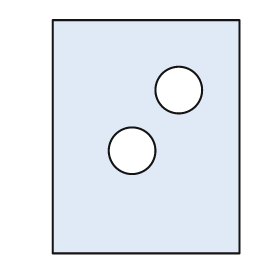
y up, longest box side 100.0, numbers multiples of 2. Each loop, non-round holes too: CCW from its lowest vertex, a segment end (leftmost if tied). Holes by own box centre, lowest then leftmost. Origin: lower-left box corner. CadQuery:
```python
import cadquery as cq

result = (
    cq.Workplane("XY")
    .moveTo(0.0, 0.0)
    .lineTo(80.0, 0.0)
    .lineTo(80.0, 100.0)
    .lineTo(0.0, 100.0)
    .close()
    .moveTo(34.0, 44.0)
    .circle(10.0)
    .moveTo(54.0, 70.0)
    .circle(10.0)
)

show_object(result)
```